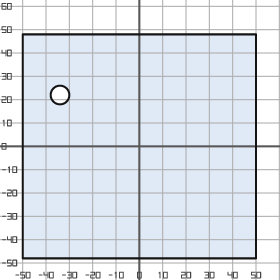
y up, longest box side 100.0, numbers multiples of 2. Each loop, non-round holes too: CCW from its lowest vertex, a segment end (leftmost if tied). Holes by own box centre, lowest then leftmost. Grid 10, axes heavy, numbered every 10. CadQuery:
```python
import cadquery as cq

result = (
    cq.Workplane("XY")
    .moveTo(-50.0, -48.0)
    .lineTo(50.0, -48.0)
    .lineTo(50.0, 48.0)
    .lineTo(-50.0, 48.0)
    .close()
    .moveTo(-34.0, 22.0)
    .circle(4.0)
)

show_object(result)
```